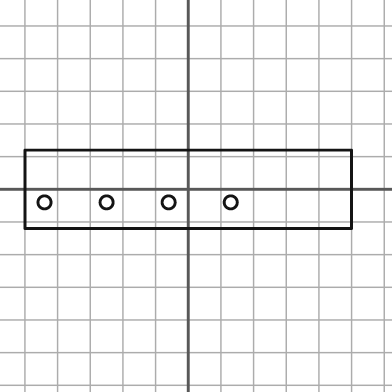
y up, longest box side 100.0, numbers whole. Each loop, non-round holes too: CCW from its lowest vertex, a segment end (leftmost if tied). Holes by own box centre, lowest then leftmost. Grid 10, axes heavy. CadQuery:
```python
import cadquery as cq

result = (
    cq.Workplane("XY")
    .moveTo(-50.0, -12.0)
    .lineTo(50.0, -12.0)
    .lineTo(50.0, 12.0)
    .lineTo(-50.0, 12.0)
    .close()
    .moveTo(-44.0, -4.0)
    .circle(2.0)
    .moveTo(-25.0, -4.0)
    .circle(2.0)
    .moveTo(-6.0, -4.0)
    .circle(2.0)
    .moveTo(13.0, -4.0)
    .circle(2.0)
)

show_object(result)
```